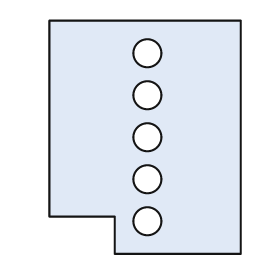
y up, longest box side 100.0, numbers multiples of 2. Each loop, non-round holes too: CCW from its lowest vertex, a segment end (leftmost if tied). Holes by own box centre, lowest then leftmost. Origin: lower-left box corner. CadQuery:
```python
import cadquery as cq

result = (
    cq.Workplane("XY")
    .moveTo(28.0, 0.0)
    .lineTo(82.0, 0.0)
    .lineTo(82.0, 100.0)
    .lineTo(0.0, 100.0)
    .lineTo(0.0, 16.0)
    .lineTo(28.0, 16.0)
    .close()
    .moveTo(42.0, 14.0)
    .circle(6.0)
    .moveTo(42.0, 32.0)
    .circle(6.0)
    .moveTo(42.0, 50.0)
    .circle(6.0)
    .moveTo(42.0, 68.0)
    .circle(6.0)
    .moveTo(42.0, 86.0)
    .circle(6.0)
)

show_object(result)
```